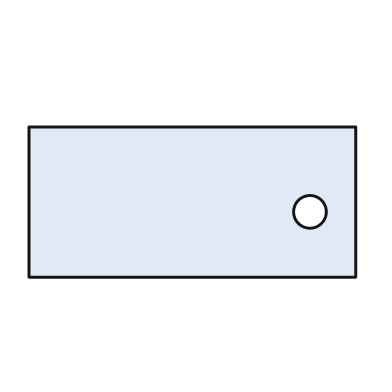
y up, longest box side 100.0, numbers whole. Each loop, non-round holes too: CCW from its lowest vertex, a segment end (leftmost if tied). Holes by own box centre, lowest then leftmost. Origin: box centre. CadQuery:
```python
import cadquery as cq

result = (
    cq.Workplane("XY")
    .moveTo(-50.0, -23.0)
    .lineTo(50.0, -23.0)
    .lineTo(50.0, 23.0)
    .lineTo(-50.0, 23.0)
    .close()
    .moveTo(36.0, -3.0)
    .circle(5.0)
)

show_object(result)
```